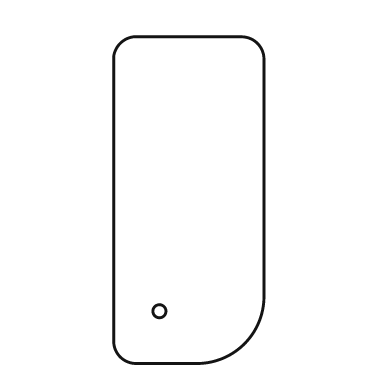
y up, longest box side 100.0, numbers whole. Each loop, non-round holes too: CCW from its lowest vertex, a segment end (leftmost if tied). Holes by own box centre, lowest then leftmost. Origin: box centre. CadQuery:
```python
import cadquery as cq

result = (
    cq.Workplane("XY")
    .moveTo(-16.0, -50.0)
    .lineTo(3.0, -50.0)
    .threePointArc((17.0, -44.0), (23.0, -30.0))
    .lineTo(23.0, 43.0)
    .threePointArc((21.0, 48.0), (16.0, 50.0))
    .lineTo(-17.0, 50.0)
    .threePointArc((-21.0, 48.0), (-23.0, 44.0))
    .lineTo(-23.0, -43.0)
    .threePointArc((-21.0, -48.0), (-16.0, -50.0))
    .close()
    .moveTo(-9.0, -34.0)
    .circle(2.0)
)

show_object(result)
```